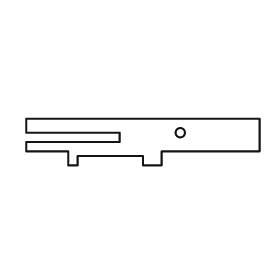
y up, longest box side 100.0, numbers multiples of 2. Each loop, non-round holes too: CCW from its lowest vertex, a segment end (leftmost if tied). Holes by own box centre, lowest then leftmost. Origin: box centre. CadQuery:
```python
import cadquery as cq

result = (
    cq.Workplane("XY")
    .moveTo(-32.0, -10.0)
    .lineTo(-28.0, -10.0)
    .lineTo(-28.0, -6.0)
    .lineTo(0.0, -6.0)
    .lineTo(0.0, -10.0)
    .lineTo(8.0, -10.0)
    .lineTo(8.0, -4.0)
    .lineTo(50.0, -4.0)
    .lineTo(50.0, 10.0)
    .lineTo(-50.0, 10.0)
    .lineTo(-50.0, 4.0)
    .lineTo(-10.0, 4.0)
    .lineTo(-10.0, 0.0)
    .lineTo(-50.0, 0.0)
    .lineTo(-50.0, -4.0)
    .lineTo(-32.0, -4.0)
    .close()
    .moveTo(16.0, 4.0)
    .circle(2.0)
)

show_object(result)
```